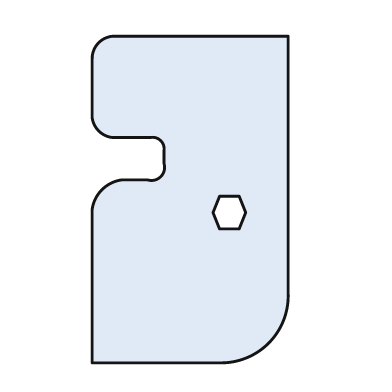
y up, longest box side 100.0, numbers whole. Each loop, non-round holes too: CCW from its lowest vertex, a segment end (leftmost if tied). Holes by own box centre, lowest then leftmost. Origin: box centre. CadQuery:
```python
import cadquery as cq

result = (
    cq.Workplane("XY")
    .moveTo(-30.0, -50.0)
    .lineTo(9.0, -50.0)
    .threePointArc((24.0, -44.0), (30.0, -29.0))
    .lineTo(30.0, 50.0)
    .lineTo(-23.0, 50.0)
    .threePointArc((-28.0, 48.0), (-30.0, 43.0))
    .lineTo(-30.0, 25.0)
    .threePointArc((-28.0, 21.0), (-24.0, 19.0))
    .lineTo(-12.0, 19.0)
    .threePointArc((-9.0, 18.0), (-8.0, 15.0))
    .lineTo(-8.0, 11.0)
    .threePointArc((-9.0, 7.0), (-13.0, 6.0))
    .lineTo(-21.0, 6.0)
    .threePointArc((-27.0, 3.0), (-30.0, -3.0))
    .close()
    .moveTo(9.0, -9.0)
    .lineTo(15.0, -9.0)
    .lineTo(17.0, -4.0)
    .lineTo(15.0, 1.0)
    .lineTo(9.0, 1.0)
    .lineTo(7.0, -4.0)
    .close()
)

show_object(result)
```